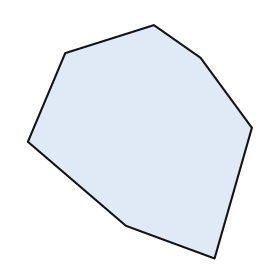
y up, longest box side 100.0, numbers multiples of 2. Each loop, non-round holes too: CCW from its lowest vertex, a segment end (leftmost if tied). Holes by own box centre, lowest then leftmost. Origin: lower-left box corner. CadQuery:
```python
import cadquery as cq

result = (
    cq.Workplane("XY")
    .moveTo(80.0, 0.0)
    .lineTo(96.0, 56.0)
    .lineTo(74.0, 86.0)
    .lineTo(54.0, 100.0)
    .lineTo(16.0, 88.0)
    .lineTo(0.0, 50.0)
    .lineTo(42.0, 14.0)
    .close()
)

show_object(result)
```